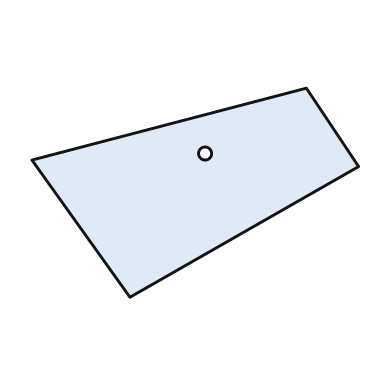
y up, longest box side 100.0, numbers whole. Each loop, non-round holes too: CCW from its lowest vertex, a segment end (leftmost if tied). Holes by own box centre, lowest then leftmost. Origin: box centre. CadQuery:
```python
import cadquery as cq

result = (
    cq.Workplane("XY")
    .moveTo(-20.0, -32.0)
    .lineTo(50.0, 8.0)
    .lineTo(34.0, 32.0)
    .lineTo(-50.0, 10.0)
    .close()
    .moveTo(3.0, 12.0)
    .circle(2.0)
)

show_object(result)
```